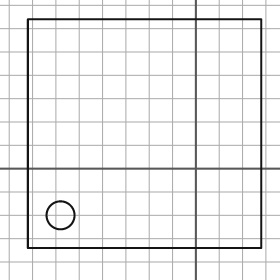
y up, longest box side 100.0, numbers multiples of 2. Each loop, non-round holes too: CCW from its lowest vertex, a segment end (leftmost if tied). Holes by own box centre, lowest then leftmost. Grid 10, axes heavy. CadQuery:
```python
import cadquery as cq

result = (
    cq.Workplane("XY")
    .moveTo(-72.0, -34.0)
    .lineTo(28.0, -34.0)
    .lineTo(28.0, 64.0)
    .lineTo(-72.0, 64.0)
    .close()
    .moveTo(-58.0, -20.0)
    .circle(6.0)
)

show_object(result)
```